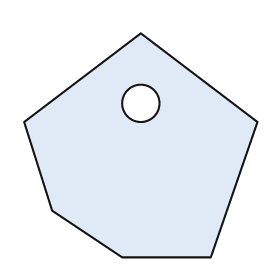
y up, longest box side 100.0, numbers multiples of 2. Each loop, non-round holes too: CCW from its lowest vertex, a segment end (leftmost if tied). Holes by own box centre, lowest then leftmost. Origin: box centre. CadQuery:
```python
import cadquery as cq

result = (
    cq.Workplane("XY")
    .moveTo(-8.0, -48.0)
    .lineTo(30.0, -48.0)
    .lineTo(50.0, 10.0)
    .lineTo(0.0, 48.0)
    .lineTo(-50.0, 10.0)
    .lineTo(-38.0, -28.0)
    .close()
    .moveTo(0.0, 18.0)
    .circle(8.0)
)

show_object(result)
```